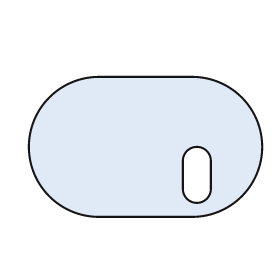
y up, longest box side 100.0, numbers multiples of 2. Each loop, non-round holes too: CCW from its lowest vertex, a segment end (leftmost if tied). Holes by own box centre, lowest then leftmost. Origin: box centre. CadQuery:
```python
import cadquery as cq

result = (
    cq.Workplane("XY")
    .moveTo(-20.0, -30.0)
    .lineTo(20.0, -30.0)
    .threePointArc((50.0, 0.0), (20.0, 30.0))
    .lineTo(-20.0, 30.0)
    .threePointArc((-50.0, 0.0), (-20.0, -30.0))
    .close()
    .moveTo(16.0, -18.0)
    .threePointArc((22.0, -24.0), (28.0, -18.0))
    .lineTo(28.0, -6.0)
    .threePointArc((22.0, 0.0), (16.0, -6.0))
    .close()
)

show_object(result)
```